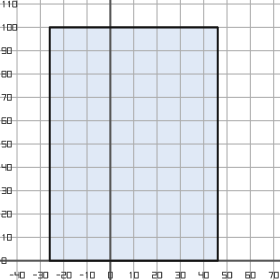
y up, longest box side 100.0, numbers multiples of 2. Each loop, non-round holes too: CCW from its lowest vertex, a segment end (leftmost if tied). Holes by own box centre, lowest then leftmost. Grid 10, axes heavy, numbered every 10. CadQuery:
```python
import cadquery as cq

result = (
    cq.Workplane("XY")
    .moveTo(-26.0, 0.0)
    .lineTo(46.0, 0.0)
    .lineTo(46.0, 100.0)
    .lineTo(-26.0, 100.0)
    .close()
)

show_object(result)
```